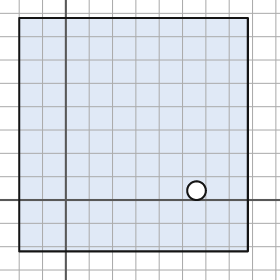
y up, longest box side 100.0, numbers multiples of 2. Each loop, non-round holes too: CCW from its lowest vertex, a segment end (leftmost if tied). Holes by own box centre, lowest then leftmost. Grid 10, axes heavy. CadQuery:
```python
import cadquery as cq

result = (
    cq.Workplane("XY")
    .moveTo(-20.0, -22.0)
    .lineTo(78.0, -22.0)
    .lineTo(78.0, 78.0)
    .lineTo(-20.0, 78.0)
    .close()
    .moveTo(56.0, 4.0)
    .circle(4.0)
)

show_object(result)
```